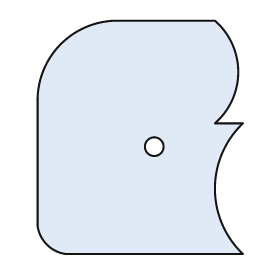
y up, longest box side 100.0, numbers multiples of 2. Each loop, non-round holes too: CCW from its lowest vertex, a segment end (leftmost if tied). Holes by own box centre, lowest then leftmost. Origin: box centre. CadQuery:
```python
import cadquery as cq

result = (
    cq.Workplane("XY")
    .moveTo(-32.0, -50.0)
    .lineTo(44.0, -50.0)
    .threePointArc((32.0, -22.0), (44.0, 6.0))
    .lineTo(32.0, 6.0)
    .threePointArc((42.0, 28.0), (32.0, 50.0))
    .lineTo(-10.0, 50.0)
    .threePointArc((-34.0, 40.0), (-44.0, 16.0))
    .lineTo(-44.0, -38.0)
    .threePointArc((-40.0, -46.0), (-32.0, -50.0))
    .close()
    .moveTo(6.0, -4.0)
    .circle(4.0)
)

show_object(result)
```